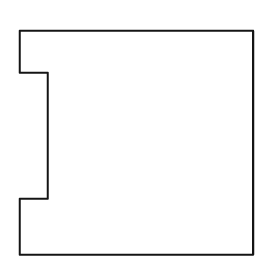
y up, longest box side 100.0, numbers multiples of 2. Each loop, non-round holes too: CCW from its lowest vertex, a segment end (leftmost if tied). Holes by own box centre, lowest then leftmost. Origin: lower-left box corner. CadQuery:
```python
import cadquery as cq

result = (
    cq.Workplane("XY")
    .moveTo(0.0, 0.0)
    .lineTo(100.0, 0.0)
    .lineTo(100.0, 96.0)
    .lineTo(0.0, 96.0)
    .lineTo(0.0, 78.0)
    .lineTo(12.0, 78.0)
    .lineTo(12.0, 24.0)
    .lineTo(0.0, 24.0)
    .close()
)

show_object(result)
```